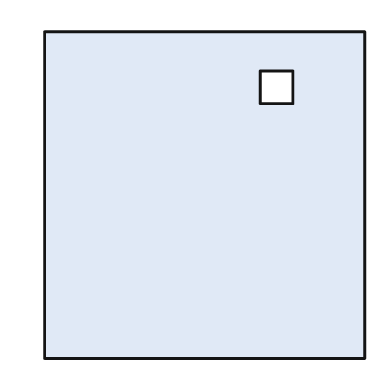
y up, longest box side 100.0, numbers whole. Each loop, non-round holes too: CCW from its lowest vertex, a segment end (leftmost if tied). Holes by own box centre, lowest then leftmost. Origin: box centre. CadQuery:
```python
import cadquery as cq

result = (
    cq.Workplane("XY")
    .moveTo(-49.0, -50.0)
    .lineTo(49.0, -50.0)
    .lineTo(49.0, 50.0)
    .lineTo(-49.0, 50.0)
    .close()
    .moveTo(17.0, 28.0)
    .lineTo(27.0, 28.0)
    .lineTo(27.0, 38.0)
    .lineTo(17.0, 38.0)
    .close()
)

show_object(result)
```